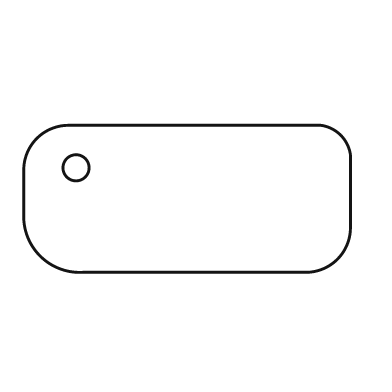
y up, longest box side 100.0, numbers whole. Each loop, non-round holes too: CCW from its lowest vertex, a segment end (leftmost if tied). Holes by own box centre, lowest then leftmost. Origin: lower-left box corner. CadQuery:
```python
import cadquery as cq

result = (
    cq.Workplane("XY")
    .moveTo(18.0, 0.0)
    .lineTo(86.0, 0.0)
    .threePointArc((96.0, 4.0), (100.0, 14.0))
    .lineTo(100.0, 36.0)
    .threePointArc((97.0, 42.0), (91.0, 45.0))
    .lineTo(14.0, 45.0)
    .threePointArc((4.0, 41.0), (0.0, 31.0))
    .lineTo(0.0, 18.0)
    .threePointArc((5.0, 5.0), (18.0, 0.0))
    .close()
    .moveTo(16.0, 32.0)
    .circle(4.0)
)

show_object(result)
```